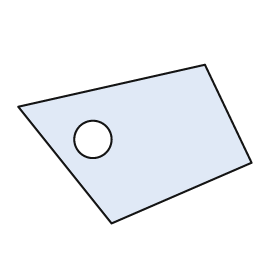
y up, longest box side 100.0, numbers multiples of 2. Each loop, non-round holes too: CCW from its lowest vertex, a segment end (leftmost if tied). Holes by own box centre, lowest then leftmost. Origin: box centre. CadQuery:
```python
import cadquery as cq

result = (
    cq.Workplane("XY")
    .moveTo(-10.0, -34.0)
    .lineTo(50.0, -8.0)
    .lineTo(30.0, 34.0)
    .lineTo(-50.0, 16.0)
    .close()
    .moveTo(-18.0, 2.0)
    .circle(8.0)
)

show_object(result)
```